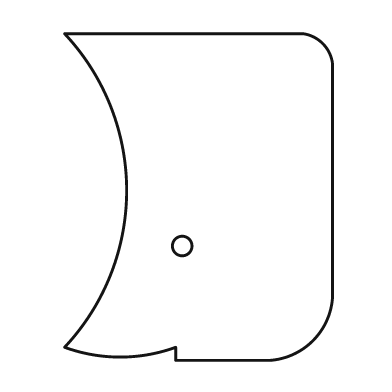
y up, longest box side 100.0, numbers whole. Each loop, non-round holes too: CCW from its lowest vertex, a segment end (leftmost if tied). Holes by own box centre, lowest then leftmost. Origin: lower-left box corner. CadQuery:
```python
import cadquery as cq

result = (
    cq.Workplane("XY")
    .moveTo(34.0, 0.0)
    .lineTo(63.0, 0.0)
    .threePointArc((76.0, 6.0), (82.0, 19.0))
    .lineTo(82.0, 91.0)
    .threePointArc((79.0, 97.0), (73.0, 100.0))
    .lineTo(0.0, 100.0)
    .threePointArc((19.0, 52.0), (0.0, 4.0))
    .threePointArc((17.0, 1.0), (34.0, 4.0))
    .close()
    .moveTo(36.0, 35.0)
    .circle(3.0)
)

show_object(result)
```